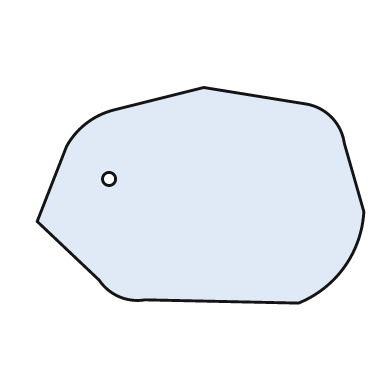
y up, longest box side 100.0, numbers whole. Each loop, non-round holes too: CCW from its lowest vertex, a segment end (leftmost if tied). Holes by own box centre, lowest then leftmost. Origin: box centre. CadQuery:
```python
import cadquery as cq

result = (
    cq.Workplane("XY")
    .moveTo(30.0, -33.0)
    .threePointArc((44.0, -22.0), (50.0, -5.0))
    .lineTo(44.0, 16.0)
    .threePointArc((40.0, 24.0), (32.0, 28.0))
    .lineTo(1.0, 33.0)
    .lineTo(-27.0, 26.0)
    .threePointArc((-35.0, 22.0), (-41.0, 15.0))
    .lineTo(-50.0, -8.0)
    .lineTo(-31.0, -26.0)
    .threePointArc((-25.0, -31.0), (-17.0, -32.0))
    .close()
    .moveTo(-28.0, 5.0)
    .circle(2.0)
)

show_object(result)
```